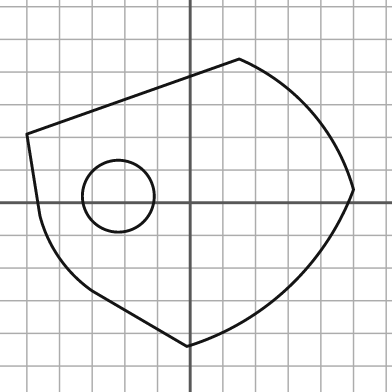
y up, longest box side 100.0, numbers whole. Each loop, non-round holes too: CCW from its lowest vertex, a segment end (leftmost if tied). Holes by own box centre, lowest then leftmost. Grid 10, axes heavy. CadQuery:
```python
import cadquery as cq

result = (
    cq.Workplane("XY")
    .moveTo(-1.0, -44.0)
    .threePointArc((30.0, -26.0), (50.0, 4.0))
    .threePointArc((37.0, 28.0), (15.0, 44.0))
    .lineTo(-50.0, 21.0)
    .lineTo(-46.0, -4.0)
    .threePointArc((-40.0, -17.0), (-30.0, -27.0))
    .close()
    .moveTo(-22.0, 2.0)
    .circle(11.0)
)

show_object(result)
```